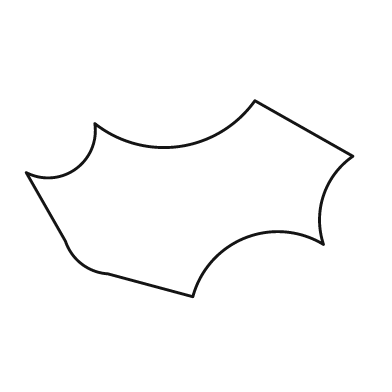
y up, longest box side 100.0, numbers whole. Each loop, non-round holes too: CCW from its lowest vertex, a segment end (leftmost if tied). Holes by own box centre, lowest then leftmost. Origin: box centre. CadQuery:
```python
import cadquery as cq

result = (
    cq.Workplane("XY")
    .moveTo(1.0, -30.0)
    .threePointArc((17.0, -12.0), (41.0, -14.0))
    .threePointArc((41.0, 1.0), (50.0, 13.0))
    .lineTo(20.0, 30.0)
    .threePointArc((-3.0, 16.0), (-29.0, 23.0))
    .threePointArc((-35.0, 9.0), (-50.0, 8.0))
    .lineTo(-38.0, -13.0)
    .threePointArc((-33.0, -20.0), (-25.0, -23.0))
    .close()
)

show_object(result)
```